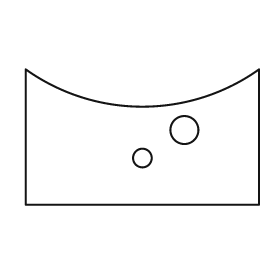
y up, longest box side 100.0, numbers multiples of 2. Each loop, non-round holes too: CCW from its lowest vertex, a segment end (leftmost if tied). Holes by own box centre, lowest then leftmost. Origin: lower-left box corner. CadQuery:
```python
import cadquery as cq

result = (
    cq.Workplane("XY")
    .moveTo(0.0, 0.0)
    .lineTo(100.0, 0.0)
    .lineTo(100.0, 58.0)
    .threePointArc((50.0, 42.0), (0.0, 58.0))
    .close()
    .moveTo(50.0, 20.0)
    .circle(4.0)
    .moveTo(68.0, 32.0)
    .circle(6.0)
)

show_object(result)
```